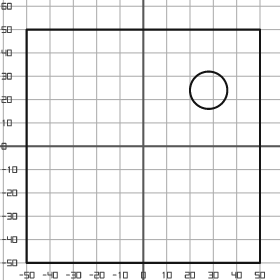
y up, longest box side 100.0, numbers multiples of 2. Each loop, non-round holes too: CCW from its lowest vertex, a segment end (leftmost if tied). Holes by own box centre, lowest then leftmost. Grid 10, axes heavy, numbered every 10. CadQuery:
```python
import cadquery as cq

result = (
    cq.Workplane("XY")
    .moveTo(-50.0, -50.0)
    .lineTo(50.0, -50.0)
    .lineTo(50.0, 50.0)
    .lineTo(-50.0, 50.0)
    .close()
    .moveTo(28.0, 24.0)
    .circle(8.0)
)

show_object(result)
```